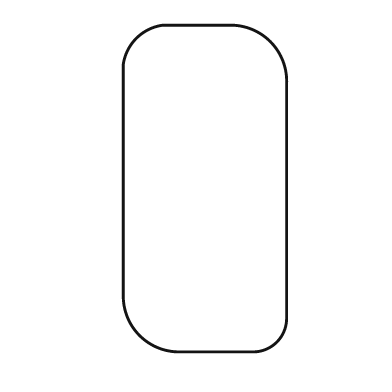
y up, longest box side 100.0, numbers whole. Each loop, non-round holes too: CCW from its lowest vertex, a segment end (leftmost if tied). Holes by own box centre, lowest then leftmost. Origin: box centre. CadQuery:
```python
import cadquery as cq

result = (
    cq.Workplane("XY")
    .moveTo(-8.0, -50.0)
    .lineTo(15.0, -50.0)
    .threePointArc((22.0, -47.0), (25.0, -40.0))
    .lineTo(25.0, 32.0)
    .threePointArc((20.0, 45.0), (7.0, 50.0))
    .lineTo(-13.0, 50.0)
    .threePointArc((-21.0, 46.0), (-25.0, 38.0))
    .lineTo(-25.0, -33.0)
    .threePointArc((-20.0, -45.0), (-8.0, -50.0))
    .close()
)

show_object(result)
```